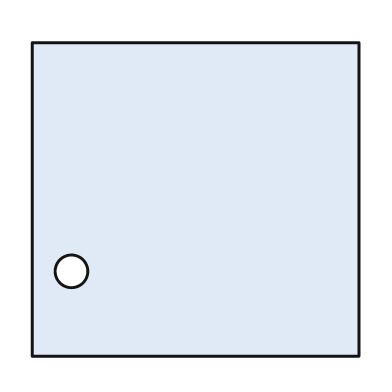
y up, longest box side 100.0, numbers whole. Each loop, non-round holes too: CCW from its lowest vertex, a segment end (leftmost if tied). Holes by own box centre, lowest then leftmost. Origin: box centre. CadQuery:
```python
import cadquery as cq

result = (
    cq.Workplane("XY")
    .moveTo(-50.0, -48.0)
    .lineTo(50.0, -48.0)
    .lineTo(50.0, 48.0)
    .lineTo(-50.0, 48.0)
    .close()
    .moveTo(-38.0, -22.0)
    .circle(5.0)
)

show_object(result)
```